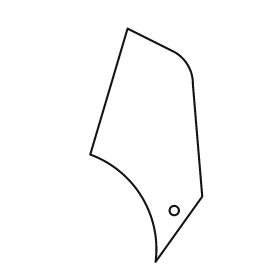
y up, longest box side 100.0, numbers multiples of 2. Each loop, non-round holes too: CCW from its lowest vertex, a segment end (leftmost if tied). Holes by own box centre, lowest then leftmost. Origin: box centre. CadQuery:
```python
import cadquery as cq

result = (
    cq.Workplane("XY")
    .moveTo(4.0, -50.0)
    .lineTo(24.0, -22.0)
    .lineTo(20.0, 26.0)
    .threePointArc((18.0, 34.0), (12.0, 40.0))
    .lineTo(-8.0, 50.0)
    .lineTo(-24.0, -4.0)
    .threePointArc((-2.0, -22.0), (4.0, -50.0))
    .close()
    .moveTo(12.0, -28.0)
    .circle(2.0)
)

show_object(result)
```